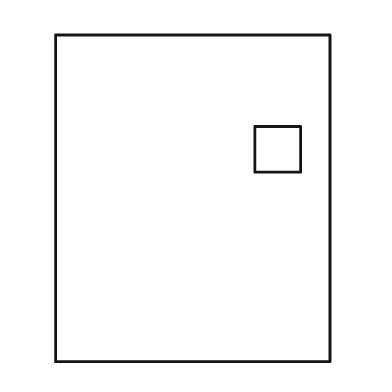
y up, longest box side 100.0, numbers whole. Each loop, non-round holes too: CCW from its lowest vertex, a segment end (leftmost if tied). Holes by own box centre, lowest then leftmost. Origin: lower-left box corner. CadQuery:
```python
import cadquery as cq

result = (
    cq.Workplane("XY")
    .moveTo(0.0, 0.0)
    .lineTo(84.0, 0.0)
    .lineTo(84.0, 100.0)
    .lineTo(0.0, 100.0)
    .close()
    .moveTo(61.0, 58.0)
    .lineTo(75.0, 58.0)
    .lineTo(75.0, 72.0)
    .lineTo(61.0, 72.0)
    .close()
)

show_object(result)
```